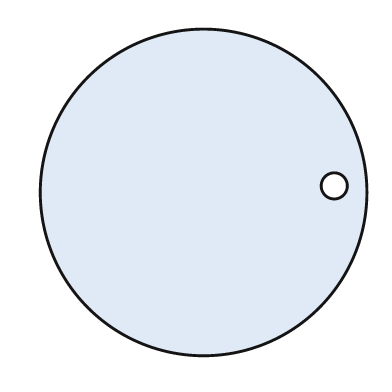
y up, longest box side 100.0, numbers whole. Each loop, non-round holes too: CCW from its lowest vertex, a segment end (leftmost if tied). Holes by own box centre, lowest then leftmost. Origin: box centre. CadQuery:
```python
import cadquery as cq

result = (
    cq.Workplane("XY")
    .moveTo(0.0, 0.0)
    .circle(50.0)
    .moveTo(40.0, 2.0)
    .circle(4.0)
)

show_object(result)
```